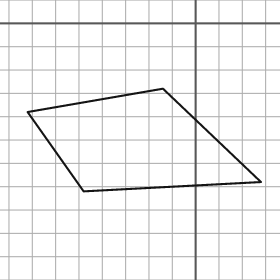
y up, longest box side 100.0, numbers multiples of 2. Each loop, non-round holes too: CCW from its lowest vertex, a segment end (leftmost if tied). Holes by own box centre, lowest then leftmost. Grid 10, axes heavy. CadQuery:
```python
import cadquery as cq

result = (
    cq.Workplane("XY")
    .moveTo(-48.0, -72.0)
    .lineTo(28.0, -68.0)
    .lineTo(-14.0, -28.0)
    .lineTo(-72.0, -38.0)
    .close()
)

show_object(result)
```